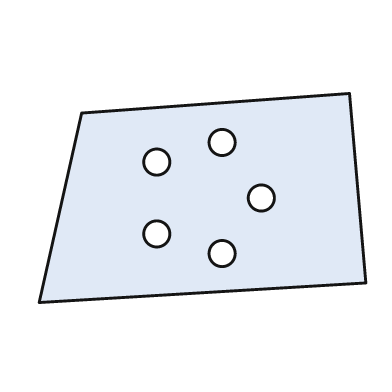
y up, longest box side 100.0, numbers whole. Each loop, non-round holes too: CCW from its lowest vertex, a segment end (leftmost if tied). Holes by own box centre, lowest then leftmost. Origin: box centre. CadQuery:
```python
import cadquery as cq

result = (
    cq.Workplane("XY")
    .moveTo(-50.0, -32.0)
    .lineTo(50.0, -26.0)
    .lineTo(45.0, 32.0)
    .lineTo(-37.0, 26.0)
    .close()
    .moveTo(6.0, -17.0)
    .circle(4.0)
    .moveTo(-14.0, -11.0)
    .circle(4.0)
    .moveTo(18.0, 0.0)
    .circle(4.0)
    .moveTo(-14.0, 11.0)
    .circle(4.0)
    .moveTo(6.0, 17.0)
    .circle(4.0)
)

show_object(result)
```